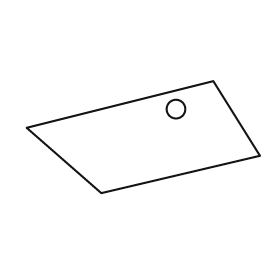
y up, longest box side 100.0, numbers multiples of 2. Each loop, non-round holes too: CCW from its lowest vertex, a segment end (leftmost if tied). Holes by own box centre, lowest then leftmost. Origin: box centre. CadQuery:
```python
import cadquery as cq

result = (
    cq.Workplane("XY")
    .moveTo(-18.0, -24.0)
    .lineTo(50.0, -8.0)
    .lineTo(30.0, 24.0)
    .lineTo(-50.0, 4.0)
    .close()
    .moveTo(14.0, 12.0)
    .circle(4.0)
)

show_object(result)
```